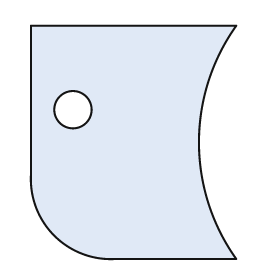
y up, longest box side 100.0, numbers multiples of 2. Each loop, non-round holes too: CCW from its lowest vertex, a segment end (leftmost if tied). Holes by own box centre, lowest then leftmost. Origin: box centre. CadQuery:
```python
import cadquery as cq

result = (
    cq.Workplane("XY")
    .moveTo(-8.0, -50.0)
    .lineTo(44.0, -50.0)
    .threePointArc((28.0, 0.0), (44.0, 50.0))
    .lineTo(-44.0, 50.0)
    .lineTo(-44.0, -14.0)
    .threePointArc((-34.0, -40.0), (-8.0, -50.0))
    .close()
    .moveTo(-26.0, 14.0)
    .circle(8.0)
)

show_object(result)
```